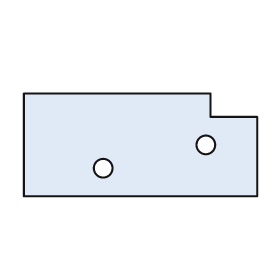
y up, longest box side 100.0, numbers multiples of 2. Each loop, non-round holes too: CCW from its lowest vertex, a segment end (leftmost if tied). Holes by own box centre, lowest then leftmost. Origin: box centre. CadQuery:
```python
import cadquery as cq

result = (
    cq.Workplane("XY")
    .moveTo(-50.0, -22.0)
    .lineTo(50.0, -22.0)
    .lineTo(50.0, 12.0)
    .lineTo(30.0, 12.0)
    .lineTo(30.0, 22.0)
    .lineTo(-50.0, 22.0)
    .close()
    .moveTo(-16.0, -10.0)
    .circle(4.0)
    .moveTo(28.0, 0.0)
    .circle(4.0)
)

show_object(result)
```